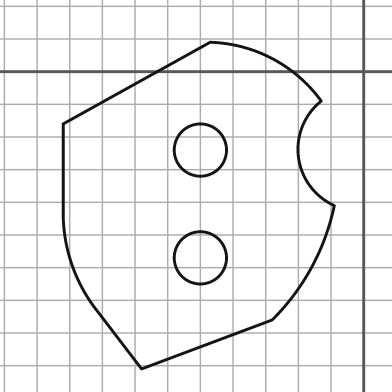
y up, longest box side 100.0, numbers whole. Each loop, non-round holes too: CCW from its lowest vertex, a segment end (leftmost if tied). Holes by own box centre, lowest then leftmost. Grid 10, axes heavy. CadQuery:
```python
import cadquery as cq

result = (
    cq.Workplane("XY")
    .moveTo(-68.0, -91.0)
    .lineTo(-28.0, -76.0)
    .threePointArc((-16.0, -60.0), (-9.0, -41.0))
    .threePointArc((-20.0, -26.0), (-13.0, -9.0))
    .threePointArc((-28.0, 4.0), (-47.0, 9.0))
    .lineTo(-92.0, -16.0)
    .lineTo(-92.0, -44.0)
    .threePointArc((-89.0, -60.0), (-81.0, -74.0))
    .close()
    .moveTo(-50.0, -57.0)
    .circle(8.0)
    .moveTo(-50.0, -24.0)
    .circle(8.0)
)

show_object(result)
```